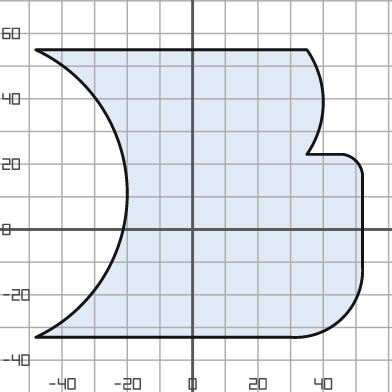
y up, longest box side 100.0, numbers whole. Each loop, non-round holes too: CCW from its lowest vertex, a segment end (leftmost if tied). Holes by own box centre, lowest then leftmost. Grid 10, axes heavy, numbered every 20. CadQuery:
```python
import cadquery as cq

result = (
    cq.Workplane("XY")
    .moveTo(-48.0, -33.0)
    .lineTo(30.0, -33.0)
    .threePointArc((46.0, -27.0), (52.0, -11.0))
    .lineTo(52.0, 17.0)
    .threePointArc((50.0, 21.0), (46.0, 23.0))
    .lineTo(35.0, 23.0)
    .threePointArc((40.0, 39.0), (35.0, 55.0))
    .lineTo(-48.0, 55.0)
    .threePointArc((-20.0, 11.0), (-48.0, -33.0))
    .close()
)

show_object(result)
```